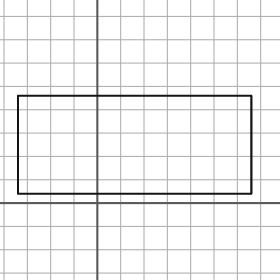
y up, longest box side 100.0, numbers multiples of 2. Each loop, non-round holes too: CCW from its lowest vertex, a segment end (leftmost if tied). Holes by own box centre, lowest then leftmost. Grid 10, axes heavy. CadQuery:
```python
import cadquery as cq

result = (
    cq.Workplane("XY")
    .moveTo(-34.0, 4.0)
    .lineTo(66.0, 4.0)
    .lineTo(66.0, 46.0)
    .lineTo(-34.0, 46.0)
    .close()
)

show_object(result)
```